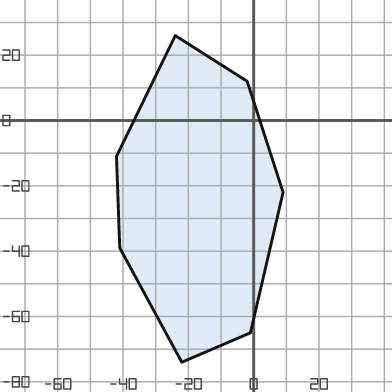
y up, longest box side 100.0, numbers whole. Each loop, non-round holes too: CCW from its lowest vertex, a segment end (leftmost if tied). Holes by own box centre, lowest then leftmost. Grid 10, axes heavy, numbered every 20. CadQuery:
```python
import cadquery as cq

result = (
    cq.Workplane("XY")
    .moveTo(-22.0, -74.0)
    .lineTo(-1.0, -65.0)
    .lineTo(9.0, -22.0)
    .lineTo(-2.0, 12.0)
    .lineTo(-24.0, 26.0)
    .lineTo(-42.0, -11.0)
    .lineTo(-41.0, -39.0)
    .close()
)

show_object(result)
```